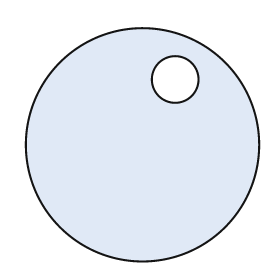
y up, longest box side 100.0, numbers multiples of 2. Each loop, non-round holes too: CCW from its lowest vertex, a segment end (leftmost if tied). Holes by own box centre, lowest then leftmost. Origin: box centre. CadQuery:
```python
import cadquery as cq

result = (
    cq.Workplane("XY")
    .moveTo(0.0, 0.0)
    .circle(50.0)
    .moveTo(14.0, 28.0)
    .circle(10.0)
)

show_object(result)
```